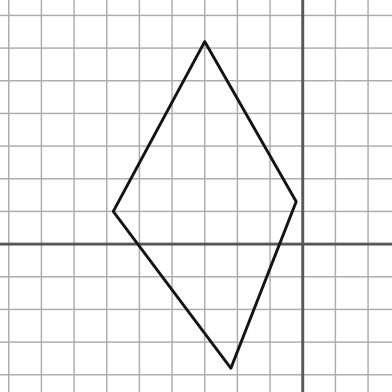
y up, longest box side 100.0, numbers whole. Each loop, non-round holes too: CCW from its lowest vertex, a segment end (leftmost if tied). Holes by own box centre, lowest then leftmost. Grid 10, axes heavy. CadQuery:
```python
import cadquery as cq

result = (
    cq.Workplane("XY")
    .moveTo(-22.0, -38.0)
    .lineTo(-2.0, 13.0)
    .lineTo(-30.0, 62.0)
    .lineTo(-58.0, 10.0)
    .close()
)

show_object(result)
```